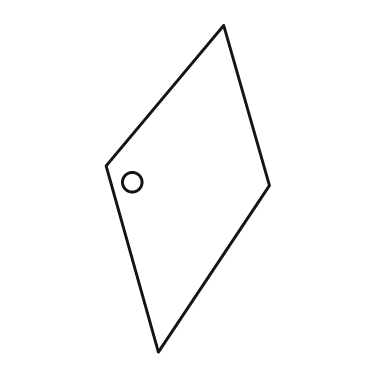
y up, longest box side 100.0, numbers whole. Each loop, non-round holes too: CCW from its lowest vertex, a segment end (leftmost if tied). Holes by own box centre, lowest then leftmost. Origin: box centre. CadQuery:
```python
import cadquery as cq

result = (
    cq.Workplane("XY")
    .moveTo(-9.0, -50.0)
    .lineTo(25.0, 1.0)
    .lineTo(11.0, 50.0)
    .lineTo(-25.0, 7.0)
    .close()
    .moveTo(-17.0, 2.0)
    .circle(3.0)
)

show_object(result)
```